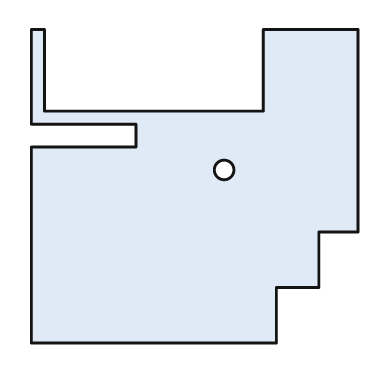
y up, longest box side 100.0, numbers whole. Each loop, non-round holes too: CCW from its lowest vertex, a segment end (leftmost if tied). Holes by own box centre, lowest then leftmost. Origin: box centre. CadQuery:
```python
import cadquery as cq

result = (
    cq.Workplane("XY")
    .moveTo(-50.0, -48.0)
    .lineTo(25.0, -48.0)
    .lineTo(25.0, -31.0)
    .lineTo(38.0, -31.0)
    .lineTo(38.0, -14.0)
    .lineTo(50.0, -14.0)
    .lineTo(50.0, 48.0)
    .lineTo(21.0, 48.0)
    .lineTo(21.0, 23.0)
    .lineTo(-46.0, 23.0)
    .lineTo(-46.0, 48.0)
    .lineTo(-50.0, 48.0)
    .lineTo(-50.0, 19.0)
    .lineTo(-18.0, 19.0)
    .lineTo(-18.0, 12.0)
    .lineTo(-50.0, 12.0)
    .close()
    .moveTo(9.0, 5.0)
    .circle(3.0)
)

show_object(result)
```